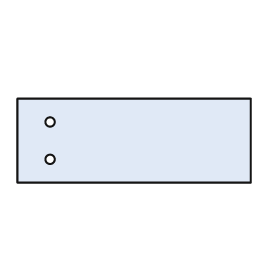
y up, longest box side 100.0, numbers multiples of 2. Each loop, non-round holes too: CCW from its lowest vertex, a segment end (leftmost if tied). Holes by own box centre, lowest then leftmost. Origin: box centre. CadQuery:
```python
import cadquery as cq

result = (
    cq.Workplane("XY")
    .moveTo(-50.0, -18.0)
    .lineTo(50.0, -18.0)
    .lineTo(50.0, 18.0)
    .lineTo(-50.0, 18.0)
    .close()
    .moveTo(-36.0, -8.0)
    .circle(2.0)
    .moveTo(-36.0, 8.0)
    .circle(2.0)
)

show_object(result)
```